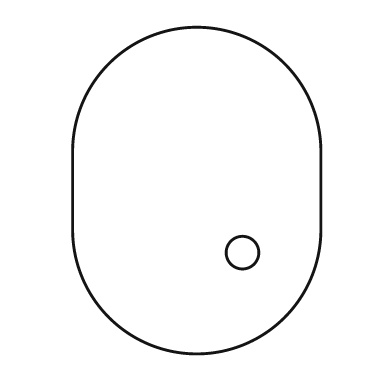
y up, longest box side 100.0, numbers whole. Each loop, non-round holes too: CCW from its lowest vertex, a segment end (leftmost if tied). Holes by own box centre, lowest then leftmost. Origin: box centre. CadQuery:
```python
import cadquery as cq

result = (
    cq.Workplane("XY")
    .moveTo(-38.0, -12.0)
    .threePointArc((0.0, -50.0), (38.0, -12.0))
    .lineTo(38.0, 12.0)
    .threePointArc((0.0, 50.0), (-38.0, 12.0))
    .close()
    .moveTo(14.0, -19.0)
    .circle(5.0)
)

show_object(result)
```